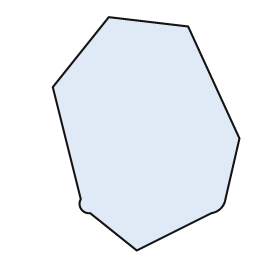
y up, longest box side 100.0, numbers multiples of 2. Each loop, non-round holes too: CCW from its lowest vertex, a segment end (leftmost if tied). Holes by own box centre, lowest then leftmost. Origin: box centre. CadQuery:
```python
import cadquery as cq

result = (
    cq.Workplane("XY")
    .moveTo(-4.0, -50.0)
    .lineTo(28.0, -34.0)
    .threePointArc((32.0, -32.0), (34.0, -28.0))
    .lineTo(40.0, -2.0)
    .lineTo(18.0, 46.0)
    .lineTo(-16.0, 50.0)
    .lineTo(-40.0, 20.0)
    .lineTo(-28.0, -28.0)
    .threePointArc((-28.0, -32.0), (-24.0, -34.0))
    .close()
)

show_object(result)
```